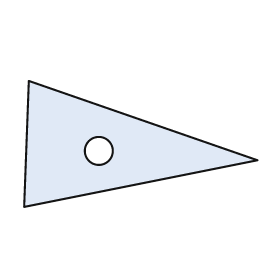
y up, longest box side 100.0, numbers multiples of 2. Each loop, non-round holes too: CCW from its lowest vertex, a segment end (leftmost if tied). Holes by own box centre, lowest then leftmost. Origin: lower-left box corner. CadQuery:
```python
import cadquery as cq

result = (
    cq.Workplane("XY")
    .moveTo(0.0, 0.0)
    .lineTo(100.0, 20.0)
    .lineTo(2.0, 54.0)
    .close()
    .moveTo(32.0, 24.0)
    .circle(6.0)
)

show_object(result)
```